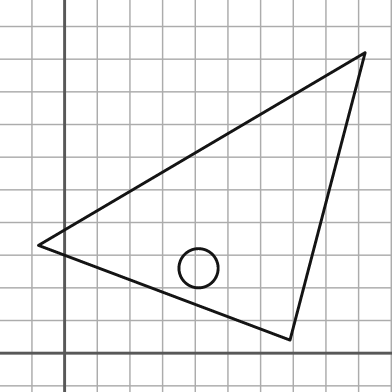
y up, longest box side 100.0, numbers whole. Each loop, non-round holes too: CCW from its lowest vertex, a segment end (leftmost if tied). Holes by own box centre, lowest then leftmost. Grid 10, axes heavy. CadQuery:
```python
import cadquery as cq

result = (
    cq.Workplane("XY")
    .moveTo(69.0, 4.0)
    .lineTo(92.0, 92.0)
    .lineTo(-8.0, 33.0)
    .close()
    .moveTo(41.0, 26.0)
    .circle(6.0)
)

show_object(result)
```